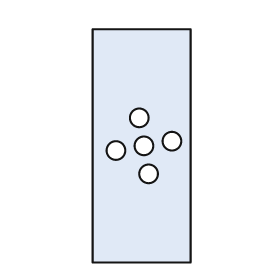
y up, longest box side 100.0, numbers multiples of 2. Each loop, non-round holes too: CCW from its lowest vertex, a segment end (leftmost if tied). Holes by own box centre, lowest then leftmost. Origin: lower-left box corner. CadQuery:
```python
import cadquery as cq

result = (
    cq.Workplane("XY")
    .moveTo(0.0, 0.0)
    .lineTo(42.0, 0.0)
    .lineTo(42.0, 100.0)
    .lineTo(0.0, 100.0)
    .close()
    .moveTo(24.0, 38.0)
    .circle(4.0)
    .moveTo(10.0, 48.0)
    .circle(4.0)
    .moveTo(22.0, 50.0)
    .circle(4.0)
    .moveTo(34.0, 52.0)
    .circle(4.0)
    .moveTo(20.0, 62.0)
    .circle(4.0)
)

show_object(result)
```